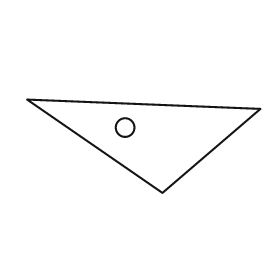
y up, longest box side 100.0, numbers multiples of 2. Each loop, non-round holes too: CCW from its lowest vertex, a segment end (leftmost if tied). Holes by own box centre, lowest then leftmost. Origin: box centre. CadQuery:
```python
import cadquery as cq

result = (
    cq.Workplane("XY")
    .moveTo(8.0, -20.0)
    .lineTo(50.0, 16.0)
    .lineTo(-50.0, 20.0)
    .close()
    .moveTo(-8.0, 8.0)
    .circle(4.0)
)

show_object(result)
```